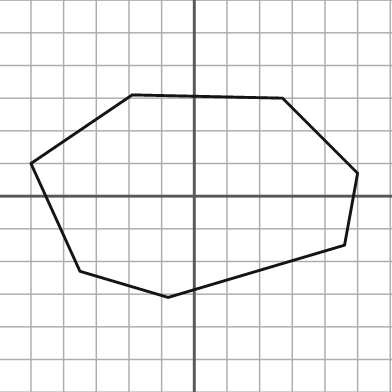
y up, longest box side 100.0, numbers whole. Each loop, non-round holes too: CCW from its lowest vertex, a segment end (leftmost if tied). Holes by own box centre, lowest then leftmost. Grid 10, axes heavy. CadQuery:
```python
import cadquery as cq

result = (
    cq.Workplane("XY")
    .moveTo(-8.0, -31.0)
    .lineTo(46.0, -15.0)
    .lineTo(50.0, 7.0)
    .lineTo(27.0, 30.0)
    .lineTo(-19.0, 31.0)
    .lineTo(-50.0, 10.0)
    .lineTo(-35.0, -23.0)
    .close()
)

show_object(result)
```